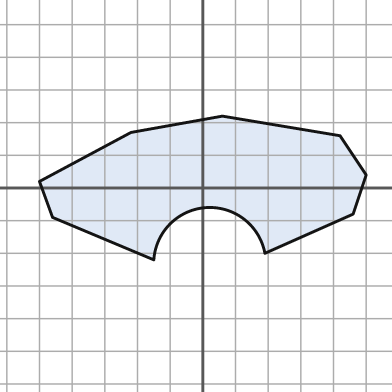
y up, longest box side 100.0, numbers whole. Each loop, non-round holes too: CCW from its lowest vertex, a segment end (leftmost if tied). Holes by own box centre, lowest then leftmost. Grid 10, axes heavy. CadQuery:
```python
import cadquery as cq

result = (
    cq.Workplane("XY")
    .moveTo(-15.0, -22.0)
    .threePointArc((1.0, -6.0), (19.0, -20.0))
    .lineTo(46.0, -8.0)
    .lineTo(50.0, 4.0)
    .lineTo(42.0, 16.0)
    .lineTo(6.0, 22.0)
    .lineTo(-22.0, 17.0)
    .lineTo(-50.0, 2.0)
    .lineTo(-46.0, -9.0)
    .close()
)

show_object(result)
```